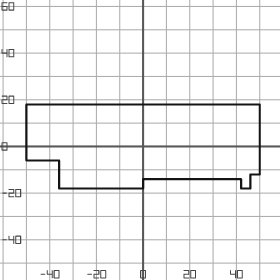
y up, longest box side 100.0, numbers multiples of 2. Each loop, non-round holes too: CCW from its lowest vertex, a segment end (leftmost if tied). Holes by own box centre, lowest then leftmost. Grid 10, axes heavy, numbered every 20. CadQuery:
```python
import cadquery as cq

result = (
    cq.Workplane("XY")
    .moveTo(-36.0, -18.0)
    .lineTo(0.0, -18.0)
    .lineTo(0.0, -14.0)
    .lineTo(42.0, -14.0)
    .lineTo(42.0, -18.0)
    .lineTo(46.0, -18.0)
    .lineTo(46.0, -12.0)
    .lineTo(50.0, -12.0)
    .lineTo(50.0, 18.0)
    .lineTo(-50.0, 18.0)
    .lineTo(-50.0, -6.0)
    .lineTo(-36.0, -6.0)
    .close()
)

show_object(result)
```